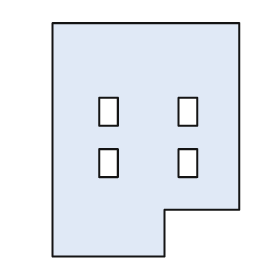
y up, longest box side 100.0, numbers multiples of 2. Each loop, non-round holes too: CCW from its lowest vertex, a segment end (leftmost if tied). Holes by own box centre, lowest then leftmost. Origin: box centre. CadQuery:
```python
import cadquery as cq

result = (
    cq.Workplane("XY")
    .moveTo(-40.0, -50.0)
    .lineTo(8.0, -50.0)
    .lineTo(8.0, -30.0)
    .lineTo(40.0, -30.0)
    .lineTo(40.0, 50.0)
    .lineTo(-40.0, 50.0)
    .close()
    .moveTo(-20.0, -16.0)
    .lineTo(-12.0, -16.0)
    .lineTo(-12.0, -4.0)
    .lineTo(-20.0, -4.0)
    .close()
    .moveTo(14.0, -16.0)
    .lineTo(22.0, -16.0)
    .lineTo(22.0, -4.0)
    .lineTo(14.0, -4.0)
    .close()
    .moveTo(-20.0, 6.0)
    .lineTo(-12.0, 6.0)
    .lineTo(-12.0, 18.0)
    .lineTo(-20.0, 18.0)
    .close()
    .moveTo(14.0, 6.0)
    .lineTo(22.0, 6.0)
    .lineTo(22.0, 18.0)
    .lineTo(14.0, 18.0)
    .close()
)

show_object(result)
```